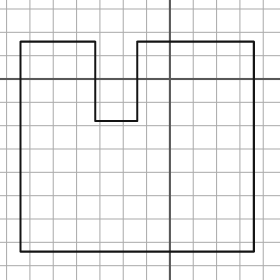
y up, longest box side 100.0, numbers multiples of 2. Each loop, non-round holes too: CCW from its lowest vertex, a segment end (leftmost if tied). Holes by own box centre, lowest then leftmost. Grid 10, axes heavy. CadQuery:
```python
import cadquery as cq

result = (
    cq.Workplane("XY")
    .moveTo(-64.0, -74.0)
    .lineTo(36.0, -74.0)
    .lineTo(36.0, 16.0)
    .lineTo(-14.0, 16.0)
    .lineTo(-14.0, -18.0)
    .lineTo(-32.0, -18.0)
    .lineTo(-32.0, 16.0)
    .lineTo(-64.0, 16.0)
    .close()
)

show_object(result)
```